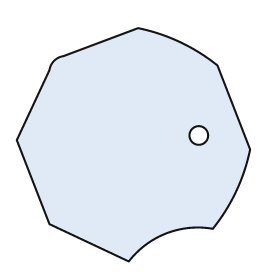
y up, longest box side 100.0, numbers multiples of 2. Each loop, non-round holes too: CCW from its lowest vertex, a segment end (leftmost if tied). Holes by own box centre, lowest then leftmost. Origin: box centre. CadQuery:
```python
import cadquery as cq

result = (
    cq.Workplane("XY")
    .moveTo(-2.0, -50.0)
    .threePointArc((14.0, -38.0), (34.0, -36.0))
    .threePointArc((44.0, -20.0), (50.0, -2.0))
    .lineTo(36.0, 34.0)
    .threePointArc((20.0, 44.0), (2.0, 50.0))
    .lineTo(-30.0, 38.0)
    .threePointArc((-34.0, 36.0), (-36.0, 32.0))
    .lineTo(-50.0, 2.0)
    .lineTo(-36.0, -34.0)
    .close()
    .moveTo(28.0, 4.0)
    .circle(4.0)
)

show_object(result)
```